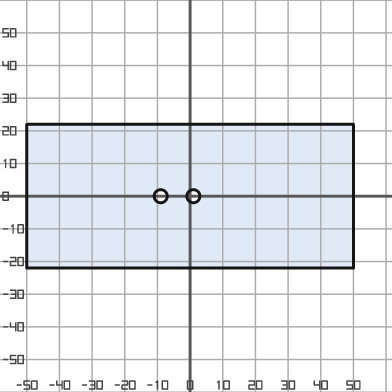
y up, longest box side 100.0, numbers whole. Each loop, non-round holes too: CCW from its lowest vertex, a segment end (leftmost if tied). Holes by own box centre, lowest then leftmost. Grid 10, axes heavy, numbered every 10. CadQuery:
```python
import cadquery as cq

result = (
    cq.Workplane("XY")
    .moveTo(-50.0, -22.0)
    .lineTo(50.0, -22.0)
    .lineTo(50.0, 22.0)
    .lineTo(-50.0, 22.0)
    .close()
    .moveTo(-9.0, 0.0)
    .circle(2.0)
    .moveTo(1.0, 0.0)
    .circle(2.0)
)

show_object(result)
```